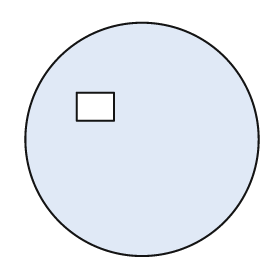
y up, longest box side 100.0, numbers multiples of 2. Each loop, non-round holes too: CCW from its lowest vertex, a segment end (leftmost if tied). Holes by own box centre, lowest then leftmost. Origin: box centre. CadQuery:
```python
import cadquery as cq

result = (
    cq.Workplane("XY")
    .moveTo(0.0, 0.0)
    .circle(50.0)
    .moveTo(-28.0, 8.0)
    .lineTo(-12.0, 8.0)
    .lineTo(-12.0, 20.0)
    .lineTo(-28.0, 20.0)
    .close()
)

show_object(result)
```